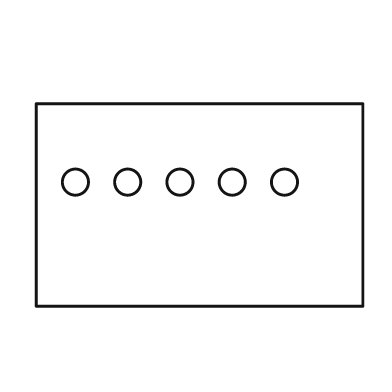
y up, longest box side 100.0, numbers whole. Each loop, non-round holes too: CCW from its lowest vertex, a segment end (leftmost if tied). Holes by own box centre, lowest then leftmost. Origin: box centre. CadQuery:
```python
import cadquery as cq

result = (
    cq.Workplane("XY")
    .moveTo(-50.0, -31.0)
    .lineTo(50.0, -31.0)
    .lineTo(50.0, 31.0)
    .lineTo(-50.0, 31.0)
    .close()
    .moveTo(-38.0, 7.0)
    .circle(4.0)
    .moveTo(-22.0, 7.0)
    .circle(4.0)
    .moveTo(-6.0, 7.0)
    .circle(4.0)
    .moveTo(10.0, 7.0)
    .circle(4.0)
    .moveTo(26.0, 7.0)
    .circle(4.0)
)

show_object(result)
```